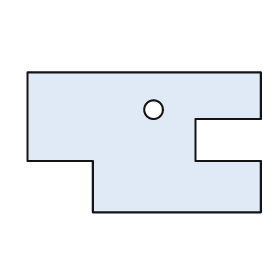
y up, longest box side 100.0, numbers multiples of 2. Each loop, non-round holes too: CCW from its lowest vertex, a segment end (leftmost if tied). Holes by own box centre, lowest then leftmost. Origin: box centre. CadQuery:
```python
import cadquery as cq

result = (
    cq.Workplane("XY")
    .moveTo(-22.0, -30.0)
    .lineTo(50.0, -30.0)
    .lineTo(50.0, -8.0)
    .lineTo(22.0, -8.0)
    .lineTo(22.0, 10.0)
    .lineTo(50.0, 10.0)
    .lineTo(50.0, 30.0)
    .lineTo(-50.0, 30.0)
    .lineTo(-50.0, -8.0)
    .lineTo(-22.0, -8.0)
    .close()
    .moveTo(4.0, 14.0)
    .circle(4.0)
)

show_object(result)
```